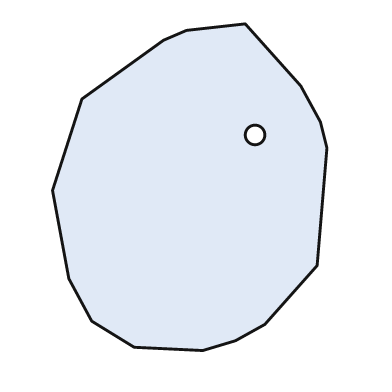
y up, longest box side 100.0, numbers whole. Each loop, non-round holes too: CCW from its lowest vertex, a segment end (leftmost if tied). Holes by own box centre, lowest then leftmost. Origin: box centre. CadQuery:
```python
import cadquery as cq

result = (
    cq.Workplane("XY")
    .moveTo(4.0, -50.0)
    .lineTo(14.0, -47.0)
    .lineTo(23.0, -42.0)
    .lineTo(39.0, -24.0)
    .lineTo(42.0, 12.0)
    .lineTo(40.0, 20.0)
    .lineTo(34.0, 31.0)
    .lineTo(17.0, 50.0)
    .lineTo(-1.0, 48.0)
    .lineTo(-8.0, 45.0)
    .lineTo(-33.0, 27.0)
    .lineTo(-42.0, -1.0)
    .lineTo(-37.0, -28.0)
    .lineTo(-30.0, -41.0)
    .lineTo(-17.0, -49.0)
    .close()
    .moveTo(20.0, 16.0)
    .circle(3.0)
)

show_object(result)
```